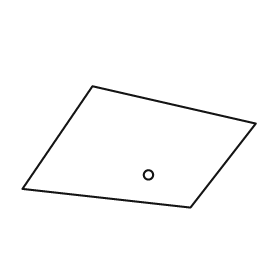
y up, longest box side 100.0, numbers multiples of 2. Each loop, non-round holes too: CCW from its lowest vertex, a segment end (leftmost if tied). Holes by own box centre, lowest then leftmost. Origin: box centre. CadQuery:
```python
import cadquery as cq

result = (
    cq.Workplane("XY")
    .moveTo(22.0, -26.0)
    .lineTo(50.0, 10.0)
    .lineTo(-20.0, 26.0)
    .lineTo(-50.0, -18.0)
    .close()
    .moveTo(4.0, -12.0)
    .circle(2.0)
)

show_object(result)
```